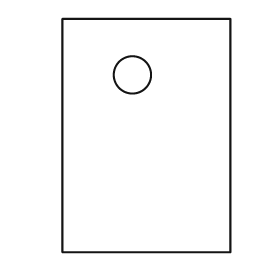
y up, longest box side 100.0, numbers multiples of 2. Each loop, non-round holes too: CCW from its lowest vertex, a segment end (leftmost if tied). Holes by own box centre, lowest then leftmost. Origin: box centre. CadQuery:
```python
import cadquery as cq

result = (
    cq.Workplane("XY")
    .moveTo(-36.0, -50.0)
    .lineTo(36.0, -50.0)
    .lineTo(36.0, 50.0)
    .lineTo(-36.0, 50.0)
    .close()
    .moveTo(-6.0, 26.0)
    .circle(8.0)
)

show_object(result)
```